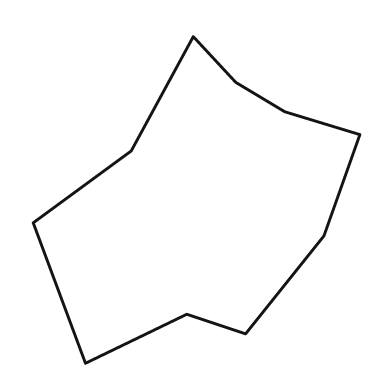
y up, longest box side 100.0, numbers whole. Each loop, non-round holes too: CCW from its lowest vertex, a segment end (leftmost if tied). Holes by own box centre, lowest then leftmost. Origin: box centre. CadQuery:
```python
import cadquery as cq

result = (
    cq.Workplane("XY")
    .moveTo(-34.0, -50.0)
    .lineTo(-3.0, -35.0)
    .lineTo(15.0, -41.0)
    .lineTo(39.0, -11.0)
    .lineTo(50.0, 20.0)
    .lineTo(27.0, 27.0)
    .lineTo(12.0, 36.0)
    .lineTo(-1.0, 50.0)
    .lineTo(-20.0, 15.0)
    .lineTo(-50.0, -7.0)
    .close()
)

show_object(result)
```